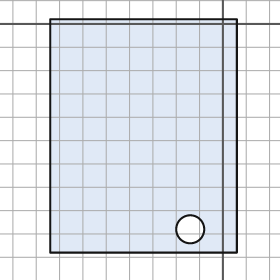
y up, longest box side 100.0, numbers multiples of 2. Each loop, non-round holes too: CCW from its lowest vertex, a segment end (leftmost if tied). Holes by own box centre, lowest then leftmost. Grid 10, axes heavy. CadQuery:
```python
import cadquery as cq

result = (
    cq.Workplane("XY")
    .moveTo(-74.0, -98.0)
    .lineTo(6.0, -98.0)
    .lineTo(6.0, 2.0)
    .lineTo(-74.0, 2.0)
    .close()
    .moveTo(-14.0, -88.0)
    .circle(6.0)
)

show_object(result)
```